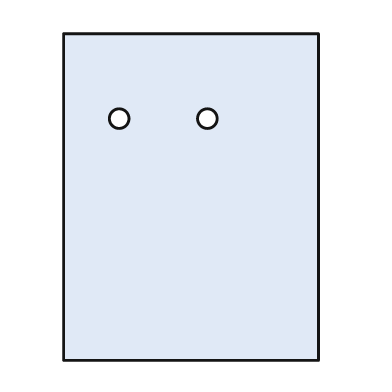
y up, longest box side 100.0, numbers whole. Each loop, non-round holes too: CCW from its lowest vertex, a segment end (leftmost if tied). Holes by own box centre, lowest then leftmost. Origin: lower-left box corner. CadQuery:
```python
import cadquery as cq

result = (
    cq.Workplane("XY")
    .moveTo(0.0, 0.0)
    .lineTo(78.0, 0.0)
    .lineTo(78.0, 100.0)
    .lineTo(0.0, 100.0)
    .close()
    .moveTo(17.0, 74.0)
    .circle(3.0)
    .moveTo(44.0, 74.0)
    .circle(3.0)
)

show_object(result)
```